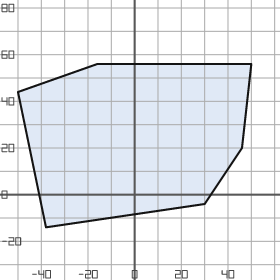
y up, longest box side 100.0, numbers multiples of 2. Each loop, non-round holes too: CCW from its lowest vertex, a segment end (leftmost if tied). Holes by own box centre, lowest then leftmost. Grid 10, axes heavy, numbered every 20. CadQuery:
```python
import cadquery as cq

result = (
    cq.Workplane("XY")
    .moveTo(-38.0, -14.0)
    .lineTo(30.0, -4.0)
    .lineTo(46.0, 20.0)
    .lineTo(50.0, 56.0)
    .lineTo(-16.0, 56.0)
    .lineTo(-50.0, 44.0)
    .close()
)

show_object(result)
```